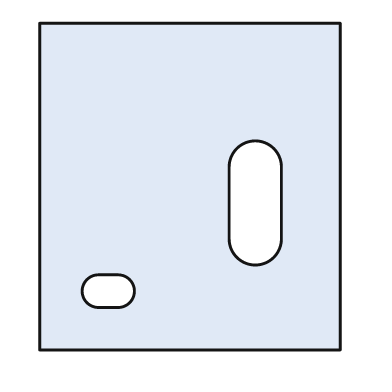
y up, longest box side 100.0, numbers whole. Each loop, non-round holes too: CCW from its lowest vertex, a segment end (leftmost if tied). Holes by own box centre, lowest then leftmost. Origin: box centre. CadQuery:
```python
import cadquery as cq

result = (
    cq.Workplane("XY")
    .moveTo(-46.0, -50.0)
    .lineTo(46.0, -50.0)
    .lineTo(46.0, 50.0)
    .lineTo(-46.0, 50.0)
    .close()
    .moveTo(-28.0, -37.0)
    .lineTo(-22.0, -37.0)
    .threePointArc((-17.0, -32.0), (-22.0, -27.0))
    .lineTo(-28.0, -27.0)
    .threePointArc((-33.0, -32.0), (-28.0, -37.0))
    .close()
    .moveTo(12.0, -16.0)
    .threePointArc((20.0, -24.0), (28.0, -16.0))
    .lineTo(28.0, 6.0)
    .threePointArc((20.0, 14.0), (12.0, 6.0))
    .close()
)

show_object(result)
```